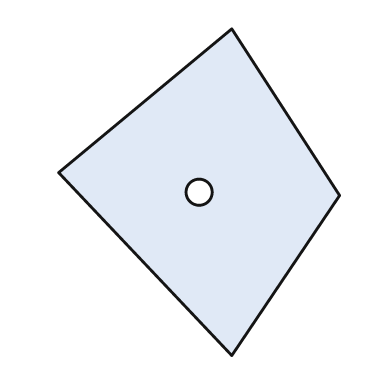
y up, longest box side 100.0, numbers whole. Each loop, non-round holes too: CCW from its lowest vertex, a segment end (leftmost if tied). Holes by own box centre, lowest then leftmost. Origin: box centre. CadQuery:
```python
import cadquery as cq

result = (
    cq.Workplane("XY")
    .moveTo(10.0, -50.0)
    .lineTo(43.0, -1.0)
    .lineTo(10.0, 50.0)
    .lineTo(-43.0, 6.0)
    .close()
    .moveTo(0.0, 0.0)
    .circle(4.0)
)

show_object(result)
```